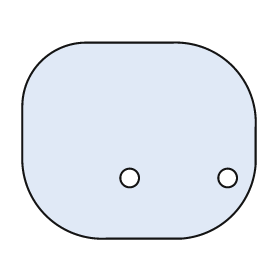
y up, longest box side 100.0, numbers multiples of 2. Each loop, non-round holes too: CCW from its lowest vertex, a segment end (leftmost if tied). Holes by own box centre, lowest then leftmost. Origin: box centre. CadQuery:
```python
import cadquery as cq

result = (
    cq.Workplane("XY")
    .moveTo(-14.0, -42.0)
    .lineTo(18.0, -42.0)
    .threePointArc((40.0, -32.0), (50.0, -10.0))
    .lineTo(50.0, 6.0)
    .threePointArc((40.0, 32.0), (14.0, 42.0))
    .lineTo(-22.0, 42.0)
    .threePointArc((-42.0, 34.0), (-50.0, 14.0))
    .lineTo(-50.0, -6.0)
    .threePointArc((-40.0, -32.0), (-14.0, -42.0))
    .close()
    .moveTo(-4.0, -16.0)
    .circle(4.0)
    .moveTo(38.0, -16.0)
    .circle(4.0)
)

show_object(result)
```